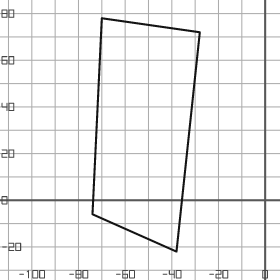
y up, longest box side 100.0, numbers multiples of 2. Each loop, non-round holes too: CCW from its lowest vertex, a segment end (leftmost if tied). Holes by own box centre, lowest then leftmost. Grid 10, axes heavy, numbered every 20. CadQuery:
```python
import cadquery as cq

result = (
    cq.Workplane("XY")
    .moveTo(-38.0, -22.0)
    .lineTo(-28.0, 72.0)
    .lineTo(-70.0, 78.0)
    .lineTo(-74.0, -6.0)
    .close()
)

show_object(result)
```